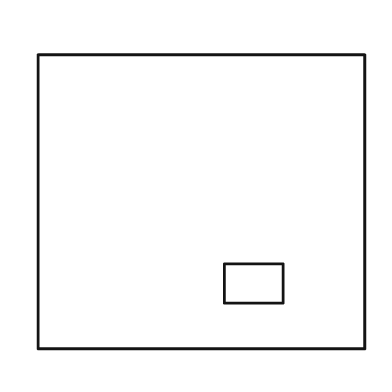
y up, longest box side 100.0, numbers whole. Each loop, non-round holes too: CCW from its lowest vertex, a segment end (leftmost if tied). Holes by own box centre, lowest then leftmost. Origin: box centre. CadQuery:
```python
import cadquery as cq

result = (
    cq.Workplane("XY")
    .moveTo(-50.0, -45.0)
    .lineTo(50.0, -45.0)
    .lineTo(50.0, 45.0)
    .lineTo(-50.0, 45.0)
    .close()
    .moveTo(7.0, -31.0)
    .lineTo(25.0, -31.0)
    .lineTo(25.0, -19.0)
    .lineTo(7.0, -19.0)
    .close()
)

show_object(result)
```